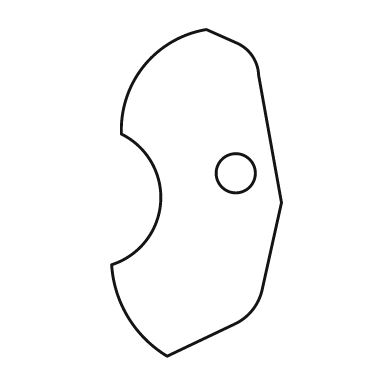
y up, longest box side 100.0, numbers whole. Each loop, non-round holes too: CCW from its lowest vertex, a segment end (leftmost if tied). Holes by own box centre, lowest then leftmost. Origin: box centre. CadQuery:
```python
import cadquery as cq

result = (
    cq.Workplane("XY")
    .moveTo(-9.0, -50.0)
    .lineTo(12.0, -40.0)
    .threePointArc((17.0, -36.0), (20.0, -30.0))
    .lineTo(26.0, -3.0)
    .lineTo(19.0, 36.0)
    .threePointArc((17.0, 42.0), (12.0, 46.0))
    .lineTo(3.0, 50.0)
    .threePointArc((-16.0, 39.0), (-23.0, 18.0))
    .threePointArc((-11.0, -3.0), (-26.0, -22.0))
    .threePointArc((-21.0, -38.0), (-9.0, -50.0))
    .close()
    .moveTo(12.0, 6.0)
    .circle(6.0)
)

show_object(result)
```